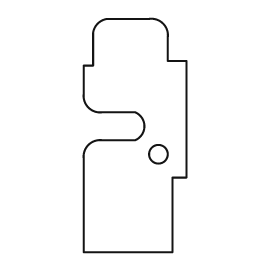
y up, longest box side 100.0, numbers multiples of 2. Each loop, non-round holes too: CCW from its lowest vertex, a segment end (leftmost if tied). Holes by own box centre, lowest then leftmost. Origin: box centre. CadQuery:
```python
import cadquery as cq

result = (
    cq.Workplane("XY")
    .moveTo(-22.0, -50.0)
    .lineTo(16.0, -50.0)
    .lineTo(16.0, -18.0)
    .lineTo(22.0, -18.0)
    .lineTo(22.0, 32.0)
    .lineTo(14.0, 32.0)
    .lineTo(14.0, 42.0)
    .threePointArc((12.0, 48.0), (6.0, 50.0))
    .lineTo(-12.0, 50.0)
    .threePointArc((-16.0, 48.0), (-18.0, 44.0))
    .lineTo(-18.0, 30.0)
    .lineTo(-22.0, 30.0)
    .lineTo(-22.0, 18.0)
    .threePointArc((-20.0, 12.0), (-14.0, 10.0))
    .lineTo(0.0, 10.0)
    .threePointArc((4.0, 4.0), (0.0, -2.0))
    .lineTo(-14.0, -2.0)
    .threePointArc((-20.0, -4.0), (-22.0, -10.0))
    .close()
    .moveTo(10.0, -8.0)
    .circle(4.0)
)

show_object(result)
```